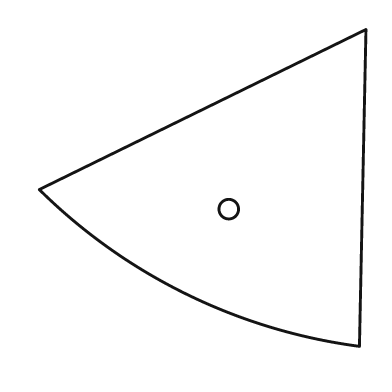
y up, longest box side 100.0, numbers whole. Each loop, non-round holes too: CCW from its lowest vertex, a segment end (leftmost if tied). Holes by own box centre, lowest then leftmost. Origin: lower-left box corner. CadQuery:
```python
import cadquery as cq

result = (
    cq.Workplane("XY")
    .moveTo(98.0, 0.0)
    .lineTo(100.0, 97.0)
    .lineTo(0.0, 48.0)
    .threePointArc((45.0, 16.0), (98.0, 0.0))
    .close()
    .moveTo(58.0, 42.0)
    .circle(3.0)
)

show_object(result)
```